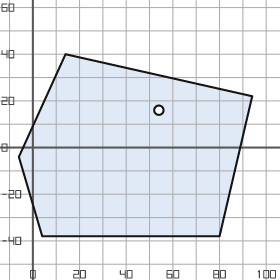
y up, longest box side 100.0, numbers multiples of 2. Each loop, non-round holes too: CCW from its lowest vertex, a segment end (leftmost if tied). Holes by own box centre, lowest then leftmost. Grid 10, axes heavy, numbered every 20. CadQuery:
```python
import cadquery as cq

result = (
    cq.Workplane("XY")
    .moveTo(4.0, -38.0)
    .lineTo(80.0, -38.0)
    .lineTo(94.0, 22.0)
    .lineTo(14.0, 40.0)
    .lineTo(-6.0, -4.0)
    .close()
    .moveTo(54.0, 16.0)
    .circle(2.0)
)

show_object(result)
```